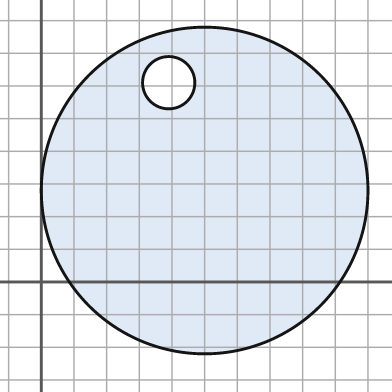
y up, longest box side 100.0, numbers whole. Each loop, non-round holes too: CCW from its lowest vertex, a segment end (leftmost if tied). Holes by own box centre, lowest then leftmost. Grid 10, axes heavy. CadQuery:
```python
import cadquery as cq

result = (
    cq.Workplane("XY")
    .moveTo(50.0, 28.0)
    .circle(50.0)
    .moveTo(39.0, 61.0)
    .circle(8.0)
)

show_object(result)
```